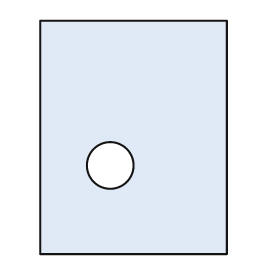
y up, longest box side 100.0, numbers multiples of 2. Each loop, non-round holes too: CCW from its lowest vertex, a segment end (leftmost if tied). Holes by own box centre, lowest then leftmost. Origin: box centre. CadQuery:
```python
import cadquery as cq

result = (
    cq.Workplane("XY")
    .moveTo(-40.0, -50.0)
    .lineTo(40.0, -50.0)
    .lineTo(40.0, 50.0)
    .lineTo(-40.0, 50.0)
    .close()
    .moveTo(-10.0, -12.0)
    .circle(10.0)
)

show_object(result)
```